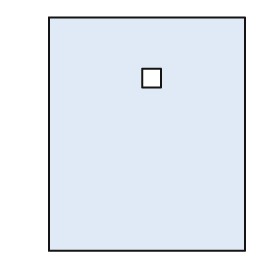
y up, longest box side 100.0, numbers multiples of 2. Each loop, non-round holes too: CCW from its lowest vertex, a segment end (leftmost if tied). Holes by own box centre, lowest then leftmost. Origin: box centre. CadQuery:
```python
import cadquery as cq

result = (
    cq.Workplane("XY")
    .moveTo(-42.0, -50.0)
    .lineTo(42.0, -50.0)
    .lineTo(42.0, 50.0)
    .lineTo(-42.0, 50.0)
    .close()
    .moveTo(-2.0, 20.0)
    .lineTo(6.0, 20.0)
    .lineTo(6.0, 28.0)
    .lineTo(-2.0, 28.0)
    .close()
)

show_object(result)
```